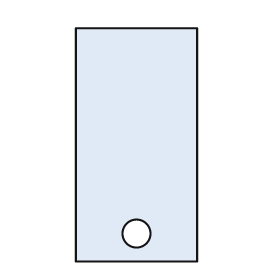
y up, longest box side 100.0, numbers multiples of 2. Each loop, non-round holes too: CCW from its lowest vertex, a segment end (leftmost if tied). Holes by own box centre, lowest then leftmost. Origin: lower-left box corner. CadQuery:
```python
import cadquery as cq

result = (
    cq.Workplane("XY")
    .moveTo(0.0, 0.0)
    .lineTo(52.0, 0.0)
    .lineTo(52.0, 100.0)
    .lineTo(0.0, 100.0)
    .close()
    .moveTo(26.0, 12.0)
    .circle(6.0)
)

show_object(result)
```